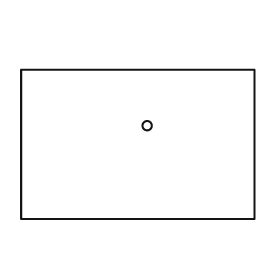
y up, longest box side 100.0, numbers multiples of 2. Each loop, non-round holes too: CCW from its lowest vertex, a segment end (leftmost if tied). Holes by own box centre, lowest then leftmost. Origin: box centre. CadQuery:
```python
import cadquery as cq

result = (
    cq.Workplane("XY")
    .moveTo(-50.0, -32.0)
    .lineTo(50.0, -32.0)
    .lineTo(50.0, 32.0)
    .lineTo(-50.0, 32.0)
    .close()
    .moveTo(4.0, 8.0)
    .circle(2.0)
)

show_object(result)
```